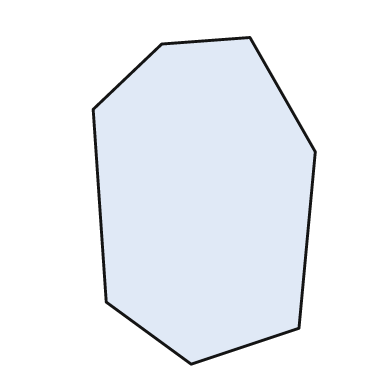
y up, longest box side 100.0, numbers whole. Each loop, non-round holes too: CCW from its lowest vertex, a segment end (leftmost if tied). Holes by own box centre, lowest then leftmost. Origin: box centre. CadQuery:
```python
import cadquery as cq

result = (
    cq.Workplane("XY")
    .moveTo(-4.0, -50.0)
    .lineTo(29.0, -39.0)
    .lineTo(34.0, 15.0)
    .lineTo(14.0, 50.0)
    .lineTo(-13.0, 48.0)
    .lineTo(-34.0, 28.0)
    .lineTo(-30.0, -31.0)
    .close()
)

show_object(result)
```